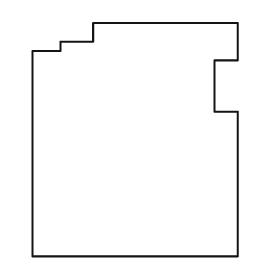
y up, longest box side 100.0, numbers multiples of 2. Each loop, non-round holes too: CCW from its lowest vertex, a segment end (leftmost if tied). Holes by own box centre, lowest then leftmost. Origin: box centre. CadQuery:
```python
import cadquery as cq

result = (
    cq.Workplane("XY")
    .moveTo(-44.0, -50.0)
    .lineTo(44.0, -50.0)
    .lineTo(44.0, 12.0)
    .lineTo(34.0, 12.0)
    .lineTo(34.0, 34.0)
    .lineTo(44.0, 34.0)
    .lineTo(44.0, 50.0)
    .lineTo(-18.0, 50.0)
    .lineTo(-18.0, 42.0)
    .lineTo(-32.0, 42.0)
    .lineTo(-32.0, 38.0)
    .lineTo(-44.0, 38.0)
    .close()
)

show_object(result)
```